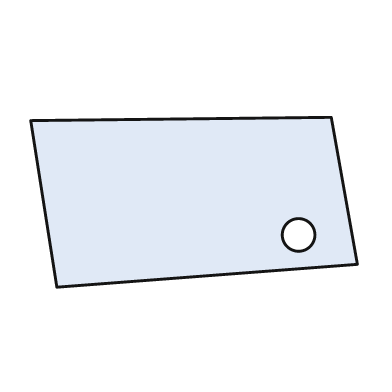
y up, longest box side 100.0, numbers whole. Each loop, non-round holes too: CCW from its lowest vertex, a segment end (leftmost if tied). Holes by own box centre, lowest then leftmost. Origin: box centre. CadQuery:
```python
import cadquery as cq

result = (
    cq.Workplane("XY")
    .moveTo(-42.0, -26.0)
    .lineTo(50.0, -19.0)
    .lineTo(42.0, 26.0)
    .lineTo(-50.0, 25.0)
    .close()
    .moveTo(32.0, -10.0)
    .circle(5.0)
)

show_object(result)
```